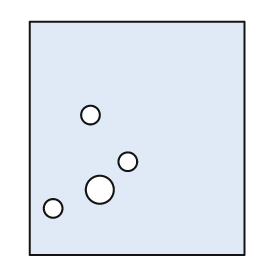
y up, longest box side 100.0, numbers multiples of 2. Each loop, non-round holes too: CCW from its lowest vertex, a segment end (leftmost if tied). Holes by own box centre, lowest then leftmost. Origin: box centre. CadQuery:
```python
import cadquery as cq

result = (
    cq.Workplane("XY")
    .moveTo(-46.0, -50.0)
    .lineTo(46.0, -50.0)
    .lineTo(46.0, 50.0)
    .lineTo(-46.0, 50.0)
    .close()
    .moveTo(-36.0, -30.0)
    .circle(4.0)
    .moveTo(-16.0, -22.0)
    .circle(6.0)
    .moveTo(-4.0, -10.0)
    .circle(4.0)
    .moveTo(-20.0, 10.0)
    .circle(4.0)
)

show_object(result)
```